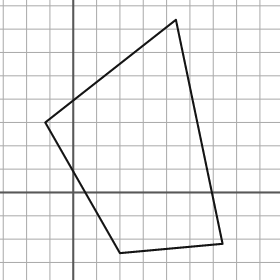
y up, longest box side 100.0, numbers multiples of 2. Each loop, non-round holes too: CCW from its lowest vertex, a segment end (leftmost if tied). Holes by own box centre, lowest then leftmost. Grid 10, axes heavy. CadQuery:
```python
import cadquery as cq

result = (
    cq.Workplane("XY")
    .moveTo(20.0, -26.0)
    .lineTo(64.0, -22.0)
    .lineTo(44.0, 74.0)
    .lineTo(-12.0, 30.0)
    .close()
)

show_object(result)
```